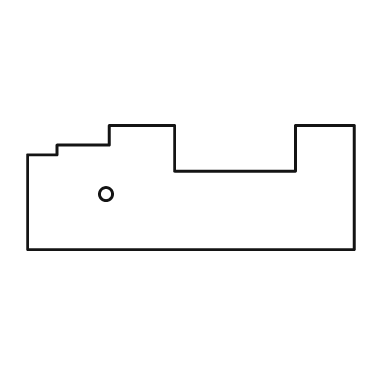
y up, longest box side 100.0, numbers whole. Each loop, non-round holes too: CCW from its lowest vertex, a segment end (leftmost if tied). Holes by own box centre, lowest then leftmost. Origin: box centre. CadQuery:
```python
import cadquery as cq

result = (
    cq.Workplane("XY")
    .moveTo(-50.0, -19.0)
    .lineTo(50.0, -19.0)
    .lineTo(50.0, 19.0)
    .lineTo(32.0, 19.0)
    .lineTo(32.0, 5.0)
    .lineTo(-5.0, 5.0)
    .lineTo(-5.0, 19.0)
    .lineTo(-25.0, 19.0)
    .lineTo(-25.0, 13.0)
    .lineTo(-41.0, 13.0)
    .lineTo(-41.0, 10.0)
    .lineTo(-50.0, 10.0)
    .close()
    .moveTo(-26.0, -2.0)
    .circle(2.0)
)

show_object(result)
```